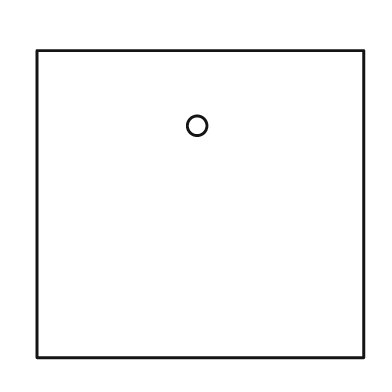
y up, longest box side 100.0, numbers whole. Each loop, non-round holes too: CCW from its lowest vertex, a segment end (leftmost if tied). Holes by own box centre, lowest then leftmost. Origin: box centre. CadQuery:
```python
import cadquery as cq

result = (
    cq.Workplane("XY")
    .moveTo(-50.0, -47.0)
    .lineTo(50.0, -47.0)
    .lineTo(50.0, 47.0)
    .lineTo(-50.0, 47.0)
    .close()
    .moveTo(-1.0, 24.0)
    .circle(3.0)
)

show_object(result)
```